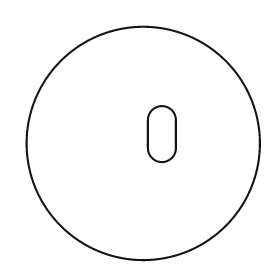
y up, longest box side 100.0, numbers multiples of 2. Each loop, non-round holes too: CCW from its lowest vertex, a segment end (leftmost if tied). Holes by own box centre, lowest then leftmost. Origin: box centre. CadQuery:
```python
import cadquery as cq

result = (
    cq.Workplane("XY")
    .moveTo(0.0, 0.0)
    .circle(50.0)
    .moveTo(2.0, -2.0)
    .threePointArc((8.0, -8.0), (14.0, -2.0))
    .lineTo(14.0, 10.0)
    .threePointArc((8.0, 16.0), (2.0, 10.0))
    .close()
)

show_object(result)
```